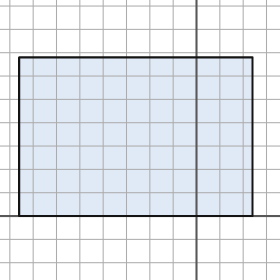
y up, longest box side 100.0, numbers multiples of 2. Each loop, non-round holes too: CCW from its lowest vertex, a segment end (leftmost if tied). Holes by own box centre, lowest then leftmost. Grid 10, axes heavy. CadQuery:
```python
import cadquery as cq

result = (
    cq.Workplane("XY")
    .moveTo(-76.0, 0.0)
    .lineTo(24.0, 0.0)
    .lineTo(24.0, 68.0)
    .lineTo(-76.0, 68.0)
    .close()
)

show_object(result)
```